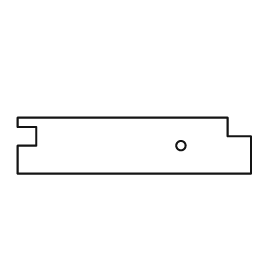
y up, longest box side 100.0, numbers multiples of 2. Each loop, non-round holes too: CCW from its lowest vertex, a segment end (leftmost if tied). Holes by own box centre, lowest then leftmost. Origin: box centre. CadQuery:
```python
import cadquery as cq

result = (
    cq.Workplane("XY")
    .moveTo(-50.0, -12.0)
    .lineTo(50.0, -12.0)
    .lineTo(50.0, 4.0)
    .lineTo(40.0, 4.0)
    .lineTo(40.0, 12.0)
    .lineTo(-50.0, 12.0)
    .lineTo(-50.0, 8.0)
    .lineTo(-42.0, 8.0)
    .lineTo(-42.0, 0.0)
    .lineTo(-50.0, 0.0)
    .close()
    .moveTo(20.0, 0.0)
    .circle(2.0)
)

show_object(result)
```